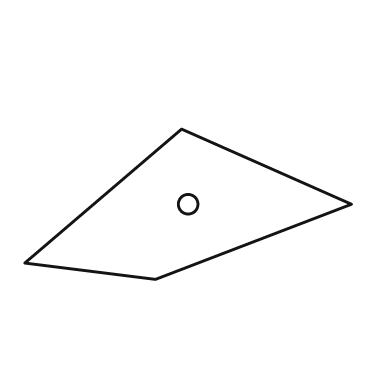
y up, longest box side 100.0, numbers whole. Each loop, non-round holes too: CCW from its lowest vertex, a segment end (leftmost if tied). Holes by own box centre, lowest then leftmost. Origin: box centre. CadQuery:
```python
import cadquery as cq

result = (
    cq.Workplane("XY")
    .moveTo(-10.0, -23.0)
    .lineTo(50.0, 0.0)
    .lineTo(-2.0, 23.0)
    .lineTo(-50.0, -18.0)
    .close()
    .moveTo(0.0, 0.0)
    .circle(3.0)
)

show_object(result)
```